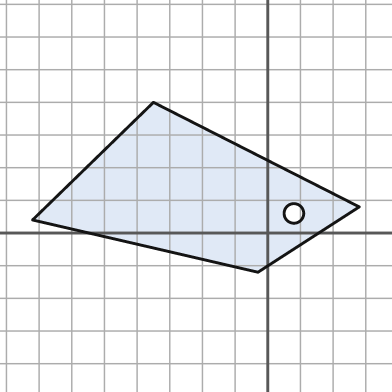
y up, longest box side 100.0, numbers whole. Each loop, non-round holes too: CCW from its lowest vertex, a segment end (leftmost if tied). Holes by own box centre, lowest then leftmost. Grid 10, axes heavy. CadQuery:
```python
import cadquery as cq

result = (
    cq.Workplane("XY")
    .moveTo(-3.0, -12.0)
    .lineTo(28.0, 8.0)
    .lineTo(-35.0, 40.0)
    .lineTo(-72.0, 4.0)
    .close()
    .moveTo(8.0, 6.0)
    .circle(3.0)
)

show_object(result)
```